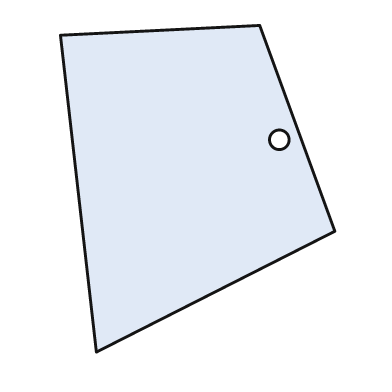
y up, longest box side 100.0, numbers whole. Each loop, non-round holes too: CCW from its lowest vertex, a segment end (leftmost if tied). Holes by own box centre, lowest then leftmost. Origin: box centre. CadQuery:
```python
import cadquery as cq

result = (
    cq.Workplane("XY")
    .moveTo(-31.0, -50.0)
    .lineTo(42.0, -13.0)
    .lineTo(19.0, 50.0)
    .lineTo(-42.0, 47.0)
    .close()
    .moveTo(25.0, 15.0)
    .circle(3.0)
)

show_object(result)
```